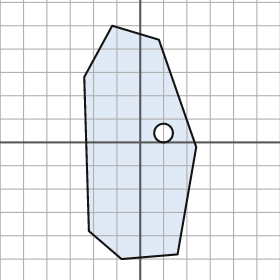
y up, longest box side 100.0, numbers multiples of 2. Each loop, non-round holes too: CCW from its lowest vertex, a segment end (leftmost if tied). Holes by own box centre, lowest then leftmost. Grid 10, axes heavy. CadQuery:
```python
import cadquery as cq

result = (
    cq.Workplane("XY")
    .moveTo(-8.0, -50.0)
    .lineTo(16.0, -48.0)
    .lineTo(24.0, -2.0)
    .lineTo(8.0, 44.0)
    .lineTo(-12.0, 50.0)
    .lineTo(-24.0, 28.0)
    .lineTo(-22.0, -38.0)
    .close()
    .moveTo(10.0, 4.0)
    .circle(4.0)
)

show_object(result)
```